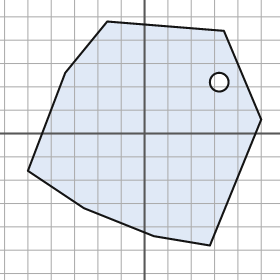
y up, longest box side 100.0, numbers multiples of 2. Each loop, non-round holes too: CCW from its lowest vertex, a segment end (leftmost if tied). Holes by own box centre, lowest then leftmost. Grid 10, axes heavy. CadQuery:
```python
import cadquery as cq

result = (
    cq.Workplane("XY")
    .moveTo(28.0, -48.0)
    .lineTo(50.0, 6.0)
    .lineTo(34.0, 44.0)
    .lineTo(-16.0, 48.0)
    .lineTo(-34.0, 26.0)
    .lineTo(-50.0, -16.0)
    .lineTo(-26.0, -32.0)
    .lineTo(4.0, -44.0)
    .close()
    .moveTo(32.0, 22.0)
    .circle(4.0)
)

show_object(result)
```